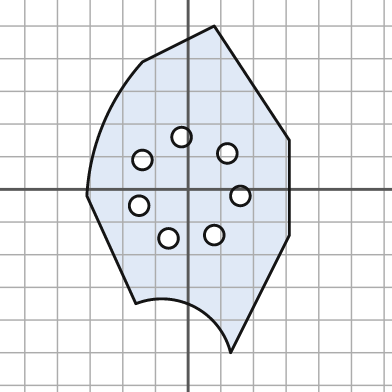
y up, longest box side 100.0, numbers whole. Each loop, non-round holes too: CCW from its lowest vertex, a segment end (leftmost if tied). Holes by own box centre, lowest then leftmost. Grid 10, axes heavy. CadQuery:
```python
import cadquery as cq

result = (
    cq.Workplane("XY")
    .moveTo(13.0, -50.0)
    .lineTo(31.0, -14.0)
    .lineTo(31.0, 15.0)
    .lineTo(8.0, 50.0)
    .lineTo(-14.0, 39.0)
    .threePointArc((-26.0, 20.0), (-31.0, -2.0))
    .lineTo(-16.0, -35.0)
    .threePointArc((2.0, -36.0), (13.0, -50.0))
    .close()
    .moveTo(-6.0, -15.0)
    .circle(3.0)
    .moveTo(8.0, -14.0)
    .circle(3.0)
    .moveTo(-15.0, -5.0)
    .circle(3.0)
    .moveTo(16.0, -2.0)
    .circle(3.0)
    .moveTo(-14.0, 9.0)
    .circle(3.0)
    .moveTo(12.0, 11.0)
    .circle(3.0)
    .moveTo(-2.0, 16.0)
    .circle(3.0)
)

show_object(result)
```